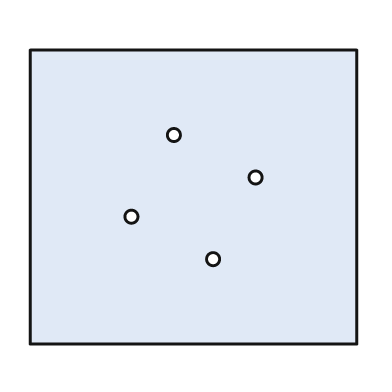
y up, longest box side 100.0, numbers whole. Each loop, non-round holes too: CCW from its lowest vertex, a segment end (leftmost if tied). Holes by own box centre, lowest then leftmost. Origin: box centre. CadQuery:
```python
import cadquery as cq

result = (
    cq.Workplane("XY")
    .moveTo(-50.0, -45.0)
    .lineTo(50.0, -45.0)
    .lineTo(50.0, 45.0)
    .lineTo(-50.0, 45.0)
    .close()
    .moveTo(6.0, -19.0)
    .circle(2.0)
    .moveTo(-19.0, -6.0)
    .circle(2.0)
    .moveTo(19.0, 6.0)
    .circle(2.0)
    .moveTo(-6.0, 19.0)
    .circle(2.0)
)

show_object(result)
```